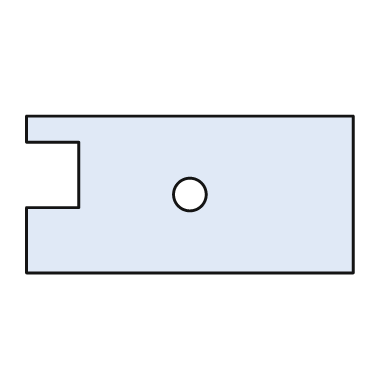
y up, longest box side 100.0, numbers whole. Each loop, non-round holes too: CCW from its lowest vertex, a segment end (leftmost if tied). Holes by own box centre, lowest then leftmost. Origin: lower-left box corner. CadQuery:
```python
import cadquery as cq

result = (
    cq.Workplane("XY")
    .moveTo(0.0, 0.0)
    .lineTo(100.0, 0.0)
    .lineTo(100.0, 48.0)
    .lineTo(0.0, 48.0)
    .lineTo(0.0, 40.0)
    .lineTo(16.0, 40.0)
    .lineTo(16.0, 20.0)
    .lineTo(0.0, 20.0)
    .close()
    .moveTo(50.0, 24.0)
    .circle(5.0)
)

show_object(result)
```